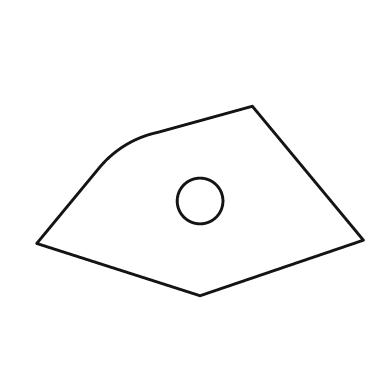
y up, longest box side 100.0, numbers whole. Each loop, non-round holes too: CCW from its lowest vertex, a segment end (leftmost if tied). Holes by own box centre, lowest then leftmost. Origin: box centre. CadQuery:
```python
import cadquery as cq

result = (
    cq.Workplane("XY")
    .moveTo(0.0, -29.0)
    .lineTo(50.0, -12.0)
    .lineTo(16.0, 29.0)
    .lineTo(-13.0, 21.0)
    .threePointArc((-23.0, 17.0), (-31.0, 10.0))
    .lineTo(-50.0, -13.0)
    .close()
    .moveTo(0.0, 0.0)
    .circle(7.0)
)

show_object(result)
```